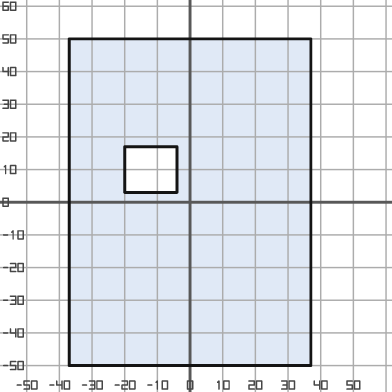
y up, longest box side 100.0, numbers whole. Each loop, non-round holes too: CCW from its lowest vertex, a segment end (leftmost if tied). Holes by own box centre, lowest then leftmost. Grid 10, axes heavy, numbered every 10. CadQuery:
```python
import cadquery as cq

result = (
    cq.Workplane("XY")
    .moveTo(-37.0, -50.0)
    .lineTo(37.0, -50.0)
    .lineTo(37.0, 50.0)
    .lineTo(-37.0, 50.0)
    .close()
    .moveTo(-20.0, 3.0)
    .lineTo(-4.0, 3.0)
    .lineTo(-4.0, 17.0)
    .lineTo(-20.0, 17.0)
    .close()
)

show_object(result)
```